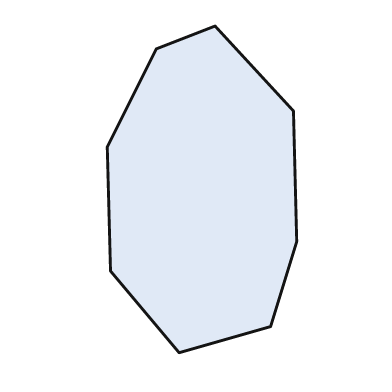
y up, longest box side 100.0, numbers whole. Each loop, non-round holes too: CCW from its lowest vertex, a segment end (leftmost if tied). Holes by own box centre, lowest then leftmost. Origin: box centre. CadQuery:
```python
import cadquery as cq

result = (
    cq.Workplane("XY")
    .moveTo(-7.0, -50.0)
    .lineTo(21.0, -42.0)
    .lineTo(29.0, -16.0)
    .lineTo(28.0, 24.0)
    .lineTo(4.0, 50.0)
    .lineTo(-14.0, 43.0)
    .lineTo(-29.0, 13.0)
    .lineTo(-28.0, -25.0)
    .close()
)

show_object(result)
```